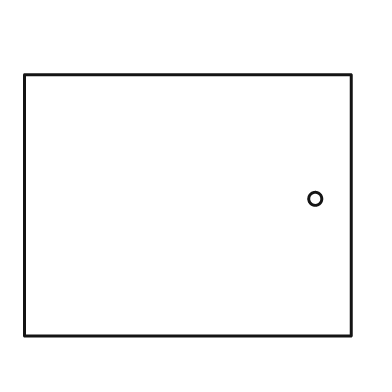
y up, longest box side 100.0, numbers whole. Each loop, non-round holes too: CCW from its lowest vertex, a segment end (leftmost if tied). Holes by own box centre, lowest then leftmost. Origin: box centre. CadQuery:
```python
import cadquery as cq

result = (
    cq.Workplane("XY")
    .moveTo(-50.0, -40.0)
    .lineTo(50.0, -40.0)
    .lineTo(50.0, 40.0)
    .lineTo(-50.0, 40.0)
    .close()
    .moveTo(39.0, 2.0)
    .circle(2.0)
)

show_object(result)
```